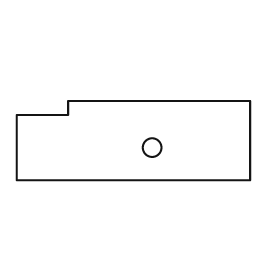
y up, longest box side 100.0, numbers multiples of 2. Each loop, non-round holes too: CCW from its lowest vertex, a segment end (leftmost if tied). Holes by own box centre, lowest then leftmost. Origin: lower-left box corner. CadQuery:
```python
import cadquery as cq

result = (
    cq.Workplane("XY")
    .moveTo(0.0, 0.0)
    .lineTo(100.0, 0.0)
    .lineTo(100.0, 34.0)
    .lineTo(22.0, 34.0)
    .lineTo(22.0, 28.0)
    .lineTo(0.0, 28.0)
    .close()
    .moveTo(58.0, 14.0)
    .circle(4.0)
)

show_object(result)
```